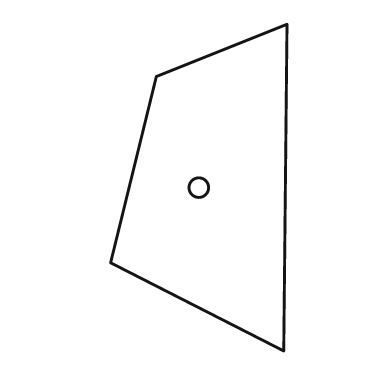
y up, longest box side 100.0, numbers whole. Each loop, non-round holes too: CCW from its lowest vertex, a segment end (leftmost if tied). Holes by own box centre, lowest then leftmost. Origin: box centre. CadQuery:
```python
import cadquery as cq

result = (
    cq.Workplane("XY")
    .moveTo(26.0, -50.0)
    .lineTo(27.0, 50.0)
    .lineTo(-13.0, 34.0)
    .lineTo(-27.0, -23.0)
    .close()
    .moveTo(0.0, 0.0)
    .circle(3.0)
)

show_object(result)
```